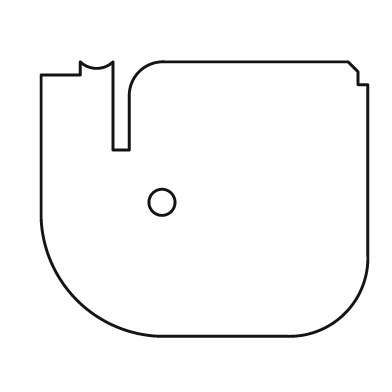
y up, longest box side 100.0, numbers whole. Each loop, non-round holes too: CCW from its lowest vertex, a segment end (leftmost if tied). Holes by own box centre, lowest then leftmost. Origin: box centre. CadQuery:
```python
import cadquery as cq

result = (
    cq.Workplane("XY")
    .moveTo(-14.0, -42.0)
    .lineTo(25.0, -42.0)
    .threePointArc((43.0, -35.0), (50.0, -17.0))
    .lineTo(50.0, 35.0)
    .lineTo(47.0, 35.0)
    .lineTo(47.0, 39.0)
    .lineTo(44.0, 42.0)
    .lineTo(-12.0, 42.0)
    .threePointArc((-20.0, 39.0), (-23.0, 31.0))
    .lineTo(-23.0, 15.0)
    .lineTo(-28.0, 15.0)
    .lineTo(-28.0, 42.0)
    .threePointArc((-33.0, 40.0), (-38.0, 42.0))
    .lineTo(-38.0, 38.0)
    .lineTo(-50.0, 38.0)
    .lineTo(-50.0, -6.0)
    .threePointArc((-39.0, -31.0), (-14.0, -42.0))
    .close()
    .moveTo(-13.0, -1.0)
    .circle(4.0)
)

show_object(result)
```